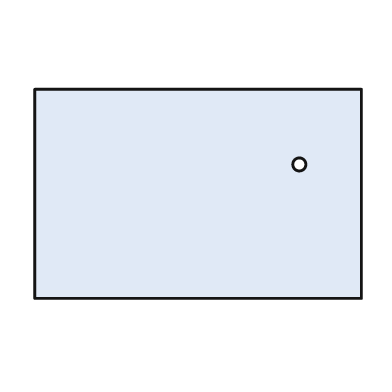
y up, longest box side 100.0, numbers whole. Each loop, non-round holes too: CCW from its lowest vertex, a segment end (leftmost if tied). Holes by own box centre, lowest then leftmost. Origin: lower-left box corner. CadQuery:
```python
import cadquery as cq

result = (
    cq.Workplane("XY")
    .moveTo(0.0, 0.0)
    .lineTo(100.0, 0.0)
    .lineTo(100.0, 64.0)
    .lineTo(0.0, 64.0)
    .close()
    .moveTo(81.0, 41.0)
    .circle(2.0)
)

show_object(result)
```